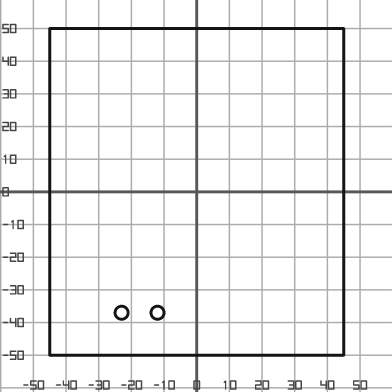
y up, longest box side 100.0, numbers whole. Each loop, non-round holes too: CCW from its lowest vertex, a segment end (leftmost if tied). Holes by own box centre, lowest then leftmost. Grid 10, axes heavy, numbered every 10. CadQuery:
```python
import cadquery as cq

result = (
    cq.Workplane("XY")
    .moveTo(-45.0, -50.0)
    .lineTo(45.0, -50.0)
    .lineTo(45.0, 50.0)
    .lineTo(-45.0, 50.0)
    .close()
    .moveTo(-23.0, -37.0)
    .circle(2.0)
    .moveTo(-12.0, -37.0)
    .circle(2.0)
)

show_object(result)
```